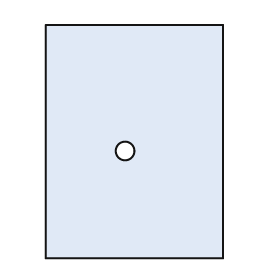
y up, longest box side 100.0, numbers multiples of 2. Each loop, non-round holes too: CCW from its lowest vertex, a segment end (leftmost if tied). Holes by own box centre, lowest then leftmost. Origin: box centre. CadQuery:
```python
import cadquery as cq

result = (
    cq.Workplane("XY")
    .moveTo(-38.0, -50.0)
    .lineTo(38.0, -50.0)
    .lineTo(38.0, 50.0)
    .lineTo(-38.0, 50.0)
    .close()
    .moveTo(-4.0, -4.0)
    .circle(4.0)
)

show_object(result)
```